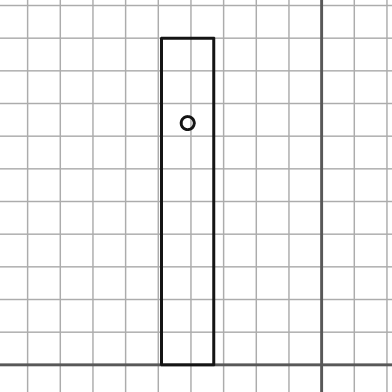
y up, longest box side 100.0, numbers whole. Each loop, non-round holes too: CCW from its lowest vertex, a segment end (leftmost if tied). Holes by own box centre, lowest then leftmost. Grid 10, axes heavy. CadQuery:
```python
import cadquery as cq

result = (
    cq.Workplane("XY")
    .moveTo(-49.0, 0.0)
    .lineTo(-33.0, 0.0)
    .lineTo(-33.0, 100.0)
    .lineTo(-49.0, 100.0)
    .close()
    .moveTo(-41.0, 74.0)
    .circle(2.0)
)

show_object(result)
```